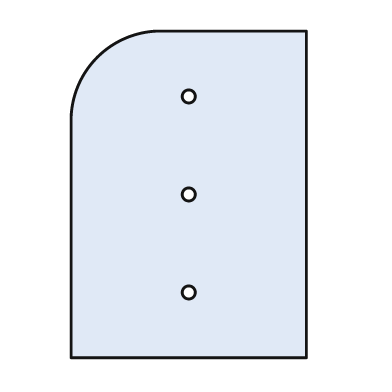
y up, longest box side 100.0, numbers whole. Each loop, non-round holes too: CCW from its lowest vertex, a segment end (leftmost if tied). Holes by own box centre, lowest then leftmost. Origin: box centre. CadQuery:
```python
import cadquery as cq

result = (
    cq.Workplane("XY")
    .moveTo(-36.0, -50.0)
    .lineTo(36.0, -50.0)
    .lineTo(36.0, 50.0)
    .lineTo(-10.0, 50.0)
    .threePointArc((-28.0, 42.0), (-36.0, 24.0))
    .close()
    .moveTo(0.0, -30.0)
    .circle(2.0)
    .moveTo(0.0, 0.0)
    .circle(2.0)
    .moveTo(0.0, 30.0)
    .circle(2.0)
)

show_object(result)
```